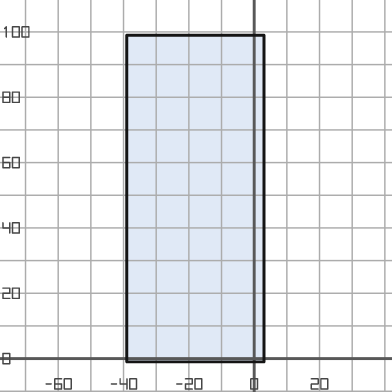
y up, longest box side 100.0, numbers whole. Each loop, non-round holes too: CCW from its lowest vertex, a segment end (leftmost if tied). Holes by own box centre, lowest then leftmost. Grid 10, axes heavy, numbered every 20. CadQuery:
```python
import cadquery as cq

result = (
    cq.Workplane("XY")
    .moveTo(-39.0, -1.0)
    .lineTo(3.0, -1.0)
    .lineTo(3.0, 99.0)
    .lineTo(-39.0, 99.0)
    .close()
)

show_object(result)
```